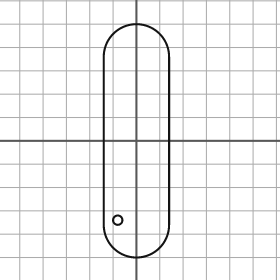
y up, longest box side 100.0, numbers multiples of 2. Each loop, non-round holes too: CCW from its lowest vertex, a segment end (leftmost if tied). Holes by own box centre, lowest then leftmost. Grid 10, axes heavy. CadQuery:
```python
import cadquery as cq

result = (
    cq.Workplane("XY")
    .moveTo(-14.0, -36.0)
    .threePointArc((0.0, -50.0), (14.0, -36.0))
    .lineTo(14.0, 36.0)
    .threePointArc((0.0, 50.0), (-14.0, 36.0))
    .close()
    .moveTo(-8.0, -34.0)
    .circle(2.0)
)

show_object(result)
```